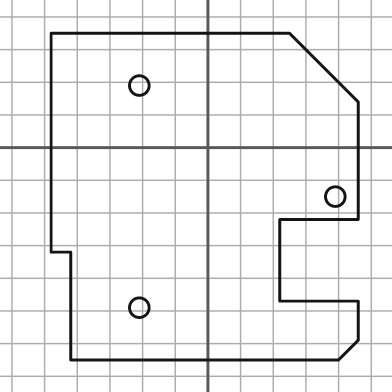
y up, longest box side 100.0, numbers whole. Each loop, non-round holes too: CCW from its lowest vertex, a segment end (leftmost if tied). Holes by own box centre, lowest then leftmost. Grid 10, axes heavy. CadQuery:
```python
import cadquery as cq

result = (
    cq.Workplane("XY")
    .moveTo(-42.0, -65.0)
    .lineTo(40.0, -65.0)
    .lineTo(46.0, -59.0)
    .lineTo(46.0, -47.0)
    .lineTo(22.0, -47.0)
    .lineTo(22.0, -22.0)
    .lineTo(46.0, -22.0)
    .lineTo(46.0, 14.0)
    .lineTo(25.0, 35.0)
    .lineTo(-48.0, 35.0)
    .lineTo(-48.0, -32.0)
    .lineTo(-42.0, -32.0)
    .close()
    .moveTo(-21.0, -49.0)
    .circle(3.0)
    .moveTo(39.0, -15.0)
    .circle(3.0)
    .moveTo(-21.0, 19.0)
    .circle(3.0)
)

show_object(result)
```